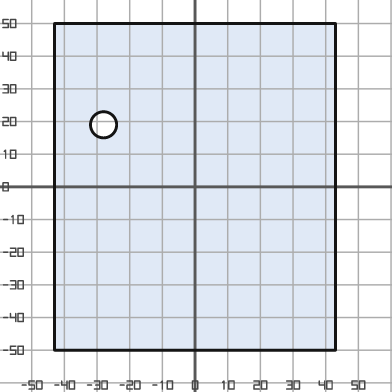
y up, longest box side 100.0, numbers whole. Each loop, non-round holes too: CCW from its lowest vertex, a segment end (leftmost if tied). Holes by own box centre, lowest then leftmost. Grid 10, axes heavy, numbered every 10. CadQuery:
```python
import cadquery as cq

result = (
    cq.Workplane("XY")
    .moveTo(-43.0, -50.0)
    .lineTo(43.0, -50.0)
    .lineTo(43.0, 50.0)
    .lineTo(-43.0, 50.0)
    .close()
    .moveTo(-28.0, 19.0)
    .circle(4.0)
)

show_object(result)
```